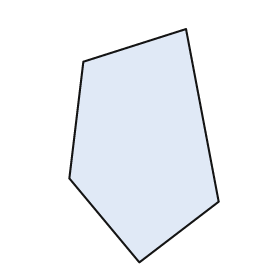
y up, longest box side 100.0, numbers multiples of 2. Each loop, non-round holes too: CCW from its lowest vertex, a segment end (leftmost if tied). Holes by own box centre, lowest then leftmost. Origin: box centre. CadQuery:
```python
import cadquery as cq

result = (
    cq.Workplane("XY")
    .moveTo(-2.0, -50.0)
    .lineTo(32.0, -24.0)
    .lineTo(18.0, 50.0)
    .lineTo(-26.0, 36.0)
    .lineTo(-32.0, -14.0)
    .close()
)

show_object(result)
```